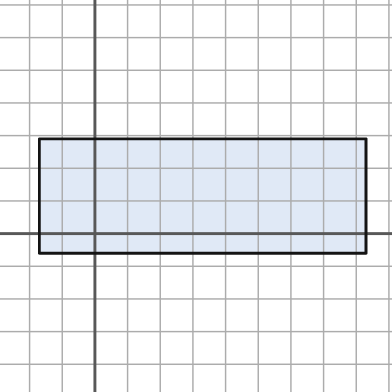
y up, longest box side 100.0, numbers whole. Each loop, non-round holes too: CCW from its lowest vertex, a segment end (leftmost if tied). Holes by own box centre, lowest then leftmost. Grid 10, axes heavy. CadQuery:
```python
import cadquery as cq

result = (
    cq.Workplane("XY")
    .moveTo(-17.0, -6.0)
    .lineTo(83.0, -6.0)
    .lineTo(83.0, 29.0)
    .lineTo(-17.0, 29.0)
    .close()
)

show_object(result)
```